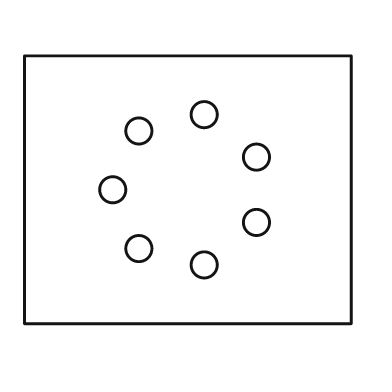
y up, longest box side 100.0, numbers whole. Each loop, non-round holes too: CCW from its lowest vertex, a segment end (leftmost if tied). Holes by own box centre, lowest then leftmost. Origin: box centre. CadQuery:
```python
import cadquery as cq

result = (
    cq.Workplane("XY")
    .moveTo(-50.0, -41.0)
    .lineTo(50.0, -41.0)
    .lineTo(50.0, 41.0)
    .lineTo(-50.0, 41.0)
    .close()
    .moveTo(5.0, -23.0)
    .circle(4.0)
    .moveTo(-15.0, -18.0)
    .circle(4.0)
    .moveTo(21.0, -10.0)
    .circle(4.0)
    .moveTo(-23.0, 0.0)
    .circle(4.0)
    .moveTo(21.0, 10.0)
    .circle(4.0)
    .moveTo(-15.0, 18.0)
    .circle(4.0)
    .moveTo(5.0, 23.0)
    .circle(4.0)
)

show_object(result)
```